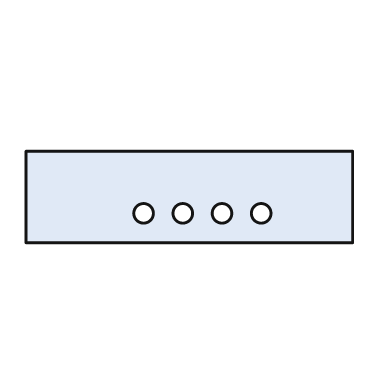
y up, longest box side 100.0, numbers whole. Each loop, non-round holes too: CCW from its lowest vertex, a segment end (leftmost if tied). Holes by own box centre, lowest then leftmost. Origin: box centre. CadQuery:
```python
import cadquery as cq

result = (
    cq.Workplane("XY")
    .moveTo(-50.0, -14.0)
    .lineTo(50.0, -14.0)
    .lineTo(50.0, 14.0)
    .lineTo(-50.0, 14.0)
    .close()
    .moveTo(-14.0, -5.0)
    .circle(3.0)
    .moveTo(-2.0, -5.0)
    .circle(3.0)
    .moveTo(10.0, -5.0)
    .circle(3.0)
    .moveTo(22.0, -5.0)
    .circle(3.0)
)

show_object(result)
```